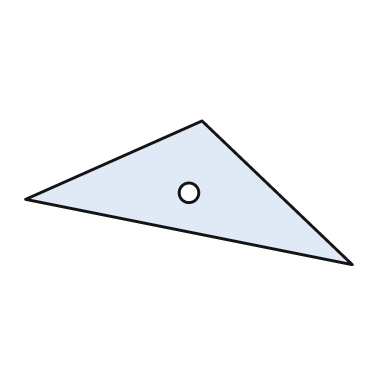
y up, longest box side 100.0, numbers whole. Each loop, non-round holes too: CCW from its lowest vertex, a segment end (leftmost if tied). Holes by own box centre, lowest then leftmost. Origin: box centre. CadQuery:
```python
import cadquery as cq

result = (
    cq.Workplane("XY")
    .moveTo(50.0, -22.0)
    .lineTo(4.0, 22.0)
    .lineTo(-50.0, -2.0)
    .close()
    .moveTo(0.0, 0.0)
    .circle(3.0)
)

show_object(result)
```